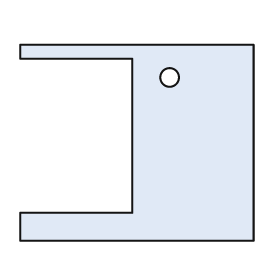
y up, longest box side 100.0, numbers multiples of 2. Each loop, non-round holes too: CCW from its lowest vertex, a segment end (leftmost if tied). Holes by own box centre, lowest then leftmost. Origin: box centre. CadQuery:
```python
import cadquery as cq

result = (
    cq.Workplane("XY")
    .moveTo(-50.0, -42.0)
    .lineTo(50.0, -42.0)
    .lineTo(50.0, 42.0)
    .lineTo(-50.0, 42.0)
    .lineTo(-50.0, 36.0)
    .lineTo(-2.0, 36.0)
    .lineTo(-2.0, -30.0)
    .lineTo(-50.0, -30.0)
    .close()
    .moveTo(14.0, 28.0)
    .circle(4.0)
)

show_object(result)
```